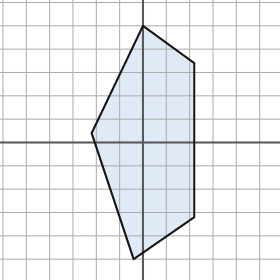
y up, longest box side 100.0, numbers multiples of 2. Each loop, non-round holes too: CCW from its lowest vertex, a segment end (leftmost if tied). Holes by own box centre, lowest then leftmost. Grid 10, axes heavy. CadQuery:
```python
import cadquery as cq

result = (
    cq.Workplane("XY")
    .moveTo(-4.0, -50.0)
    .lineTo(22.0, -32.0)
    .lineTo(22.0, 34.0)
    .lineTo(0.0, 50.0)
    .lineTo(-22.0, 4.0)
    .close()
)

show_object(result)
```